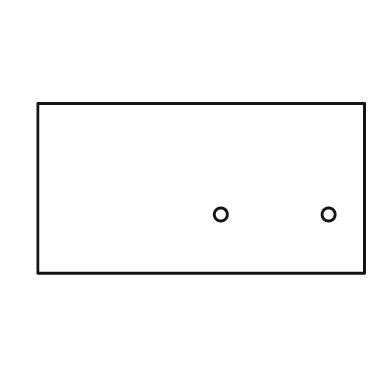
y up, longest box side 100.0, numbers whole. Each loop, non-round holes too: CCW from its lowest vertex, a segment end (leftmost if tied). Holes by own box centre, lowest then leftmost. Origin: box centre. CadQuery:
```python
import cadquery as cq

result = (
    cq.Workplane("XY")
    .moveTo(-50.0, -26.0)
    .lineTo(50.0, -26.0)
    .lineTo(50.0, 26.0)
    .lineTo(-50.0, 26.0)
    .close()
    .moveTo(6.0, -8.0)
    .circle(2.0)
    .moveTo(39.0, -8.0)
    .circle(2.0)
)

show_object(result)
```